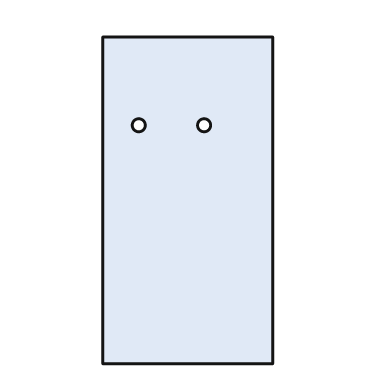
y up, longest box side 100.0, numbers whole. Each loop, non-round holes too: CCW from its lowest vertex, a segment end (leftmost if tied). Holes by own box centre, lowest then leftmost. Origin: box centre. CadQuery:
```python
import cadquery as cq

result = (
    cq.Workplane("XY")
    .moveTo(-26.0, -50.0)
    .lineTo(26.0, -50.0)
    .lineTo(26.0, 50.0)
    .lineTo(-26.0, 50.0)
    .close()
    .moveTo(-15.0, 23.0)
    .circle(2.0)
    .moveTo(5.0, 23.0)
    .circle(2.0)
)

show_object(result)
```